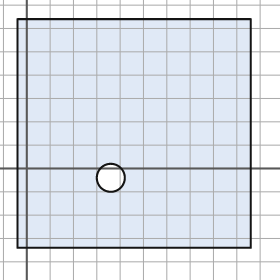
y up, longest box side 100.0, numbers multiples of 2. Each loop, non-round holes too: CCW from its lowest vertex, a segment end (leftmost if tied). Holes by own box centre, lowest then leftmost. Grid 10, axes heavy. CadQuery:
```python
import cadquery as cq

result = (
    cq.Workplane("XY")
    .moveTo(-4.0, -34.0)
    .lineTo(96.0, -34.0)
    .lineTo(96.0, 64.0)
    .lineTo(-4.0, 64.0)
    .close()
    .moveTo(36.0, -4.0)
    .circle(6.0)
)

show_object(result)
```